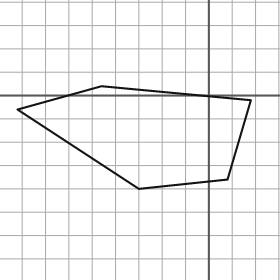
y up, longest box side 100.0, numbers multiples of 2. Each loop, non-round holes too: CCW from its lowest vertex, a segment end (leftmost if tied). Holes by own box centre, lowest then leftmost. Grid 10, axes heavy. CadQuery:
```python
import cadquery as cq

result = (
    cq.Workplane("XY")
    .moveTo(-30.0, -40.0)
    .lineTo(8.0, -36.0)
    .lineTo(18.0, -2.0)
    .lineTo(-46.0, 4.0)
    .lineTo(-82.0, -6.0)
    .close()
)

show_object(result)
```